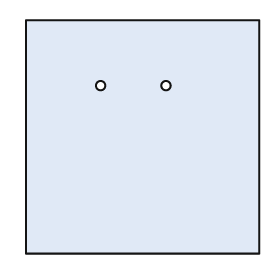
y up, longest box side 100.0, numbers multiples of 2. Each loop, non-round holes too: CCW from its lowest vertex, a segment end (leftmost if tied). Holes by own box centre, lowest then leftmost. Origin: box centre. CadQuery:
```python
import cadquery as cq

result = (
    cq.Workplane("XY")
    .moveTo(-50.0, -50.0)
    .lineTo(50.0, -50.0)
    .lineTo(50.0, 50.0)
    .lineTo(-50.0, 50.0)
    .close()
    .moveTo(-18.0, 22.0)
    .circle(2.0)
    .moveTo(10.0, 22.0)
    .circle(2.0)
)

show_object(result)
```